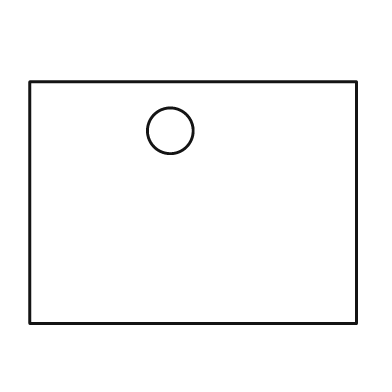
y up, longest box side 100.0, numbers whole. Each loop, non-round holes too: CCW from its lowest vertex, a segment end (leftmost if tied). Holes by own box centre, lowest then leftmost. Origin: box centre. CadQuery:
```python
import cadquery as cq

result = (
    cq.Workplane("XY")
    .moveTo(-50.0, -37.0)
    .lineTo(50.0, -37.0)
    .lineTo(50.0, 37.0)
    .lineTo(-50.0, 37.0)
    .close()
    .moveTo(-7.0, 22.0)
    .circle(7.0)
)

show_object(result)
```